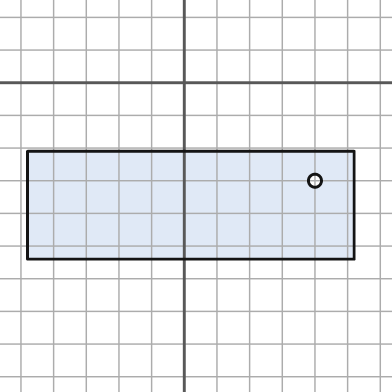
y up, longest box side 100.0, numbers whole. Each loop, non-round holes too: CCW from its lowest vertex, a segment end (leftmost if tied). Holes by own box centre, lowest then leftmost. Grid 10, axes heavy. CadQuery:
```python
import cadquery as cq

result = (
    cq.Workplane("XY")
    .moveTo(-48.0, -54.0)
    .lineTo(52.0, -54.0)
    .lineTo(52.0, -21.0)
    .lineTo(-48.0, -21.0)
    .close()
    .moveTo(40.0, -30.0)
    .circle(2.0)
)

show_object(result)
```